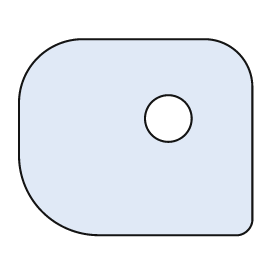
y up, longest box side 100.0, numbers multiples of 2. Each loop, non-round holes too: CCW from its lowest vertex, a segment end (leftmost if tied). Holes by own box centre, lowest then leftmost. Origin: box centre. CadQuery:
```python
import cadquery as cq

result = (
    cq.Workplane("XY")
    .moveTo(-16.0, -42.0)
    .lineTo(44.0, -42.0)
    .threePointArc((48.0, -40.0), (50.0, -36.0))
    .lineTo(50.0, 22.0)
    .threePointArc((44.0, 36.0), (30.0, 42.0))
    .lineTo(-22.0, 42.0)
    .threePointArc((-42.0, 34.0), (-50.0, 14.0))
    .lineTo(-50.0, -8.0)
    .threePointArc((-40.0, -32.0), (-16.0, -42.0))
    .close()
    .moveTo(14.0, 8.0)
    .circle(10.0)
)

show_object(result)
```